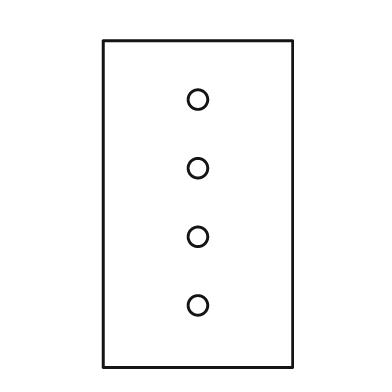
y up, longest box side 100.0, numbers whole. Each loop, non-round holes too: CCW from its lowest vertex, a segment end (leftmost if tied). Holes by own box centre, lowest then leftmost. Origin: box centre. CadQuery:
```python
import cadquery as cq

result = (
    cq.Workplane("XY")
    .moveTo(-29.0, -50.0)
    .lineTo(29.0, -50.0)
    .lineTo(29.0, 50.0)
    .lineTo(-29.0, 50.0)
    .close()
    .moveTo(0.0, -31.0)
    .circle(3.0)
    .moveTo(0.0, -10.0)
    .circle(3.0)
    .moveTo(0.0, 11.0)
    .circle(3.0)
    .moveTo(0.0, 32.0)
    .circle(3.0)
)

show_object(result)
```